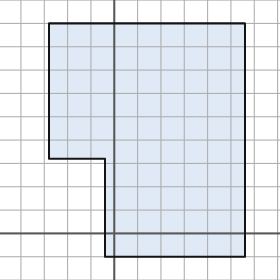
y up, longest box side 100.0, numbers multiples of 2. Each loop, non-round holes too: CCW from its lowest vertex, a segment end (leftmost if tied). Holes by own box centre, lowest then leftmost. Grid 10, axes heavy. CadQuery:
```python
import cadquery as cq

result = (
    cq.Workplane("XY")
    .moveTo(-4.0, -10.0)
    .lineTo(56.0, -10.0)
    .lineTo(56.0, 90.0)
    .lineTo(-28.0, 90.0)
    .lineTo(-28.0, 32.0)
    .lineTo(-4.0, 32.0)
    .close()
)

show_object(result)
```